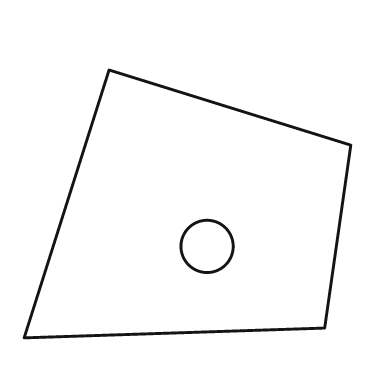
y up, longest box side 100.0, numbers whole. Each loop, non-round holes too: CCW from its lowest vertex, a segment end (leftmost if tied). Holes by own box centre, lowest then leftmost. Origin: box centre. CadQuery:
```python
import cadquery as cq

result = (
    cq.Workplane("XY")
    .moveTo(-50.0, -41.0)
    .lineTo(42.0, -38.0)
    .lineTo(50.0, 18.0)
    .lineTo(-24.0, 41.0)
    .close()
    .moveTo(6.0, -13.0)
    .circle(8.0)
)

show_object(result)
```